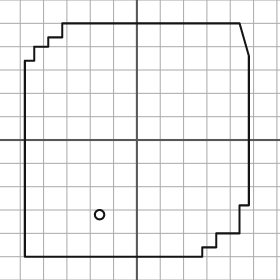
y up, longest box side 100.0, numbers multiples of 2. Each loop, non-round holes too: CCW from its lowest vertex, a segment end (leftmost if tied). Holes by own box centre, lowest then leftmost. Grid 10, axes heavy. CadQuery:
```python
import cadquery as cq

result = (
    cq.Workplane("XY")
    .moveTo(-48.0, -50.0)
    .lineTo(28.0, -50.0)
    .lineTo(28.0, -46.0)
    .lineTo(34.0, -46.0)
    .lineTo(34.0, -40.0)
    .lineTo(44.0, -40.0)
    .lineTo(44.0, -28.0)
    .lineTo(48.0, -28.0)
    .lineTo(48.0, 36.0)
    .lineTo(44.0, 50.0)
    .lineTo(-32.0, 50.0)
    .lineTo(-32.0, 44.0)
    .lineTo(-38.0, 44.0)
    .lineTo(-38.0, 40.0)
    .lineTo(-44.0, 40.0)
    .lineTo(-44.0, 34.0)
    .lineTo(-48.0, 34.0)
    .close()
    .moveTo(-16.0, -32.0)
    .circle(2.0)
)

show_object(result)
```